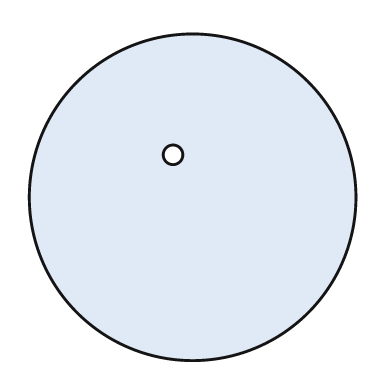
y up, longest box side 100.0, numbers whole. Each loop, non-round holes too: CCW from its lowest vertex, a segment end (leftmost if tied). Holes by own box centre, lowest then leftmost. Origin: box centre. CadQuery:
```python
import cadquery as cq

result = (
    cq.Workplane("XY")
    .moveTo(0.0, 0.0)
    .circle(50.0)
    .moveTo(-6.0, 13.0)
    .circle(3.0)
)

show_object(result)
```